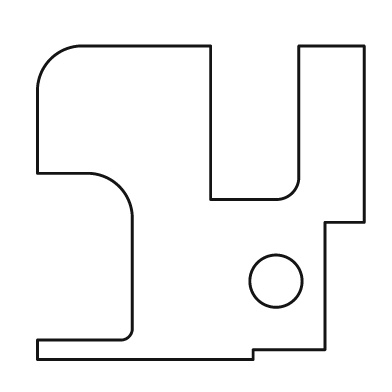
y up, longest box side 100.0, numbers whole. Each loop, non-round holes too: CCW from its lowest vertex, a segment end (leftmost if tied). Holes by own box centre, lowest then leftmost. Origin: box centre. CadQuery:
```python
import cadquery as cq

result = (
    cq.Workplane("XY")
    .moveTo(-50.0, -48.0)
    .lineTo(16.0, -48.0)
    .lineTo(16.0, -45.0)
    .lineTo(38.0, -45.0)
    .lineTo(38.0, -6.0)
    .lineTo(50.0, -6.0)
    .lineTo(50.0, 48.0)
    .lineTo(30.0, 48.0)
    .lineTo(30.0, 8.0)
    .threePointArc((28.0, 3.0), (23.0, 1.0))
    .lineTo(3.0, 1.0)
    .lineTo(3.0, 48.0)
    .lineTo(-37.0, 48.0)
    .threePointArc((-46.0, 44.0), (-50.0, 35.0))
    .lineTo(-50.0, 9.0)
    .lineTo(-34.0, 9.0)
    .threePointArc((-25.0, 5.0), (-21.0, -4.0))
    .lineTo(-21.0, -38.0)
    .threePointArc((-22.0, -41.0), (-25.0, -42.0))
    .lineTo(-50.0, -42.0)
    .close()
    .moveTo(23.0, -24.0)
    .circle(8.0)
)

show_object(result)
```